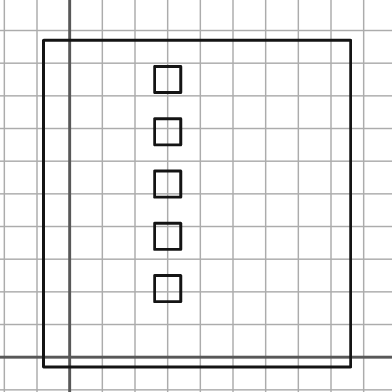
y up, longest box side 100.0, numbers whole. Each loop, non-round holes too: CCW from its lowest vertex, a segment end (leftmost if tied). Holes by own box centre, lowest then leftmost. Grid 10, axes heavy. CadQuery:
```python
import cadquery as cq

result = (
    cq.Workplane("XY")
    .moveTo(-8.0, -3.0)
    .lineTo(86.0, -3.0)
    .lineTo(86.0, 97.0)
    .lineTo(-8.0, 97.0)
    .close()
    .moveTo(26.0, 17.0)
    .lineTo(34.0, 17.0)
    .lineTo(34.0, 25.0)
    .lineTo(26.0, 25.0)
    .close()
    .moveTo(26.0, 33.0)
    .lineTo(34.0, 33.0)
    .lineTo(34.0, 41.0)
    .lineTo(26.0, 41.0)
    .close()
    .moveTo(26.0, 49.0)
    .lineTo(34.0, 49.0)
    .lineTo(34.0, 57.0)
    .lineTo(26.0, 57.0)
    .close()
    .moveTo(26.0, 65.0)
    .lineTo(34.0, 65.0)
    .lineTo(34.0, 73.0)
    .lineTo(26.0, 73.0)
    .close()
    .moveTo(26.0, 81.0)
    .lineTo(34.0, 81.0)
    .lineTo(34.0, 89.0)
    .lineTo(26.0, 89.0)
    .close()
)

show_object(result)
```